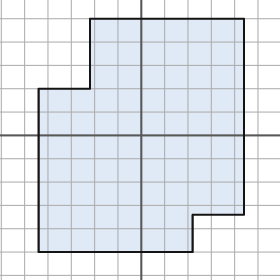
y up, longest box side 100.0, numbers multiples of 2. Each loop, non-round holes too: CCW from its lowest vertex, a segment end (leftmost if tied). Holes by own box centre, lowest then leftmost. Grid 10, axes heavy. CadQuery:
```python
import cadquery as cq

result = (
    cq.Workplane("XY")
    .moveTo(-44.0, -50.0)
    .lineTo(22.0, -50.0)
    .lineTo(22.0, -34.0)
    .lineTo(44.0, -34.0)
    .lineTo(44.0, 50.0)
    .lineTo(-22.0, 50.0)
    .lineTo(-22.0, 20.0)
    .lineTo(-44.0, 20.0)
    .close()
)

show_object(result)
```